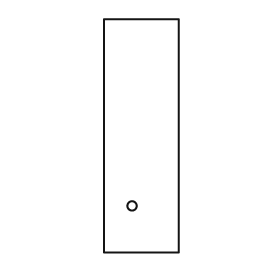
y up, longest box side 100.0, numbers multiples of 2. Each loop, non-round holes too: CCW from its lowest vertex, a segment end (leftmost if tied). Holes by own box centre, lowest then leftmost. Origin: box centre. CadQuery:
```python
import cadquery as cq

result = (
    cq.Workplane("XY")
    .moveTo(-16.0, -50.0)
    .lineTo(16.0, -50.0)
    .lineTo(16.0, 50.0)
    .lineTo(-16.0, 50.0)
    .close()
    .moveTo(-4.0, -30.0)
    .circle(2.0)
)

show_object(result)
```